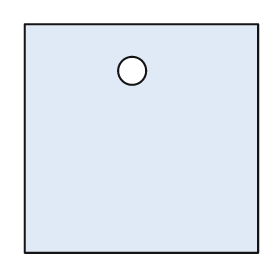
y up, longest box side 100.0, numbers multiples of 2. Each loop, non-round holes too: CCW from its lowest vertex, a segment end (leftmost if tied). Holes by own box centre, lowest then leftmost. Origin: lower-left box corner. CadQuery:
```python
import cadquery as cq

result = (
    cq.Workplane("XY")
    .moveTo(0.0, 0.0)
    .lineTo(100.0, 0.0)
    .lineTo(100.0, 98.0)
    .lineTo(0.0, 98.0)
    .close()
    .moveTo(46.0, 78.0)
    .circle(6.0)
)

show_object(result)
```